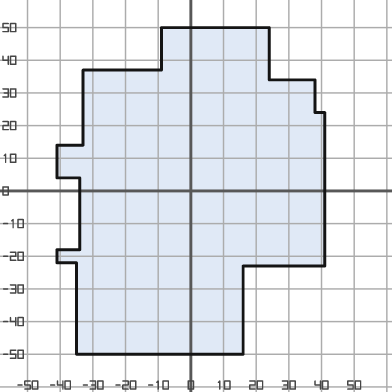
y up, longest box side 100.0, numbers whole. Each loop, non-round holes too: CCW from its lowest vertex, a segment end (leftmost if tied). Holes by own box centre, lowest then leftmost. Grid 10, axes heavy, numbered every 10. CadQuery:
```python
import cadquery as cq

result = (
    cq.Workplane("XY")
    .moveTo(-35.0, -50.0)
    .lineTo(16.0, -50.0)
    .lineTo(16.0, -23.0)
    .lineTo(41.0, -23.0)
    .lineTo(41.0, 24.0)
    .lineTo(38.0, 24.0)
    .lineTo(38.0, 34.0)
    .lineTo(24.0, 34.0)
    .lineTo(24.0, 50.0)
    .lineTo(-9.0, 50.0)
    .lineTo(-9.0, 37.0)
    .lineTo(-33.0, 37.0)
    .lineTo(-33.0, 14.0)
    .lineTo(-41.0, 14.0)
    .lineTo(-41.0, 4.0)
    .lineTo(-34.0, 4.0)
    .lineTo(-34.0, -18.0)
    .lineTo(-41.0, -18.0)
    .lineTo(-41.0, -22.0)
    .lineTo(-35.0, -22.0)
    .close()
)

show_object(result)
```